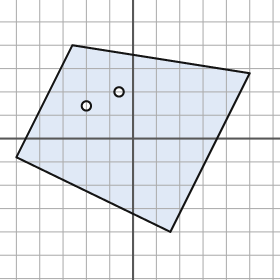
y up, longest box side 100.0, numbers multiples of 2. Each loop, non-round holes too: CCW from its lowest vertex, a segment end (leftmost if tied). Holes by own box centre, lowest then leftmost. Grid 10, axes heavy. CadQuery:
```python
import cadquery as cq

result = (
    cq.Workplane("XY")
    .moveTo(16.0, -40.0)
    .lineTo(50.0, 28.0)
    .lineTo(-26.0, 40.0)
    .lineTo(-50.0, -8.0)
    .close()
    .moveTo(-20.0, 14.0)
    .circle(2.0)
    .moveTo(-6.0, 20.0)
    .circle(2.0)
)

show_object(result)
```